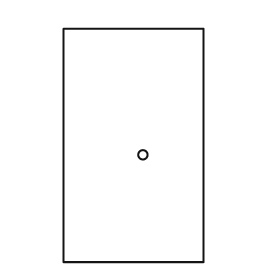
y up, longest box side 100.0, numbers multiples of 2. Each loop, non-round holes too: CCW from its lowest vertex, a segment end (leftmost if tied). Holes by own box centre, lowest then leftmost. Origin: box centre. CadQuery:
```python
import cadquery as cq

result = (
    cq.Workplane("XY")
    .moveTo(-30.0, -50.0)
    .lineTo(30.0, -50.0)
    .lineTo(30.0, 50.0)
    .lineTo(-30.0, 50.0)
    .close()
    .moveTo(4.0, -4.0)
    .circle(2.0)
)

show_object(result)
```